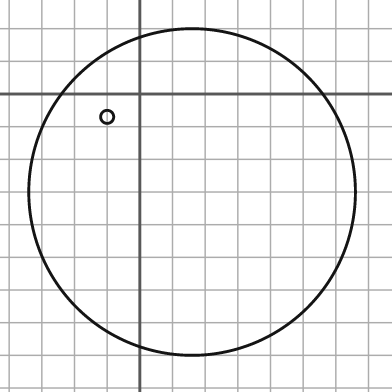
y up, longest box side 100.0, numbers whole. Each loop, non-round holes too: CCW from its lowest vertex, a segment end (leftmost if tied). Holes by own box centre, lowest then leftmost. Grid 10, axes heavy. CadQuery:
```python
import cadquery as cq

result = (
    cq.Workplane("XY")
    .moveTo(16.0, -30.0)
    .circle(50.0)
    .moveTo(-10.0, -7.0)
    .circle(2.0)
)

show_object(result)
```